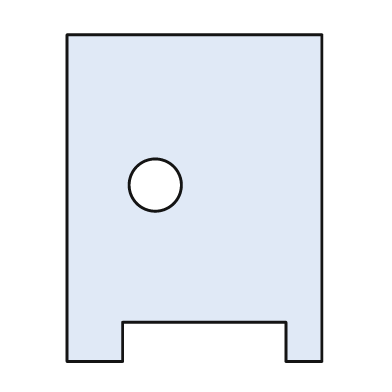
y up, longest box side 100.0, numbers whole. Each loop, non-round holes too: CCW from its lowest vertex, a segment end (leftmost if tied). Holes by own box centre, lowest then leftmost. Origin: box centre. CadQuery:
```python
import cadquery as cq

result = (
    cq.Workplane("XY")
    .moveTo(-39.0, -50.0)
    .lineTo(-22.0, -50.0)
    .lineTo(-22.0, -38.0)
    .lineTo(28.0, -38.0)
    .lineTo(28.0, -50.0)
    .lineTo(39.0, -50.0)
    .lineTo(39.0, 50.0)
    .lineTo(-39.0, 50.0)
    .close()
    .moveTo(-12.0, 4.0)
    .circle(8.0)
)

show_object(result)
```